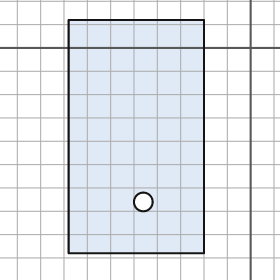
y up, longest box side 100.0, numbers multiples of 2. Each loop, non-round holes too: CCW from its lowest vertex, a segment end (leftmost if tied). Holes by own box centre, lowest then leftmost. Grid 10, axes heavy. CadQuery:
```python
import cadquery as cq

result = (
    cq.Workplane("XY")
    .moveTo(-78.0, -88.0)
    .lineTo(-20.0, -88.0)
    .lineTo(-20.0, 12.0)
    .lineTo(-78.0, 12.0)
    .close()
    .moveTo(-46.0, -66.0)
    .circle(4.0)
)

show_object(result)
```